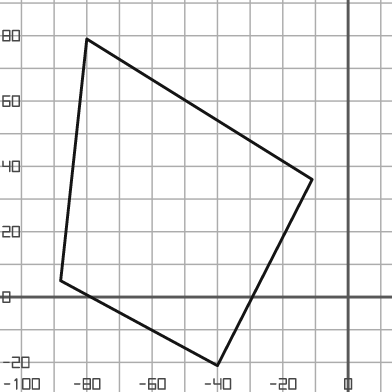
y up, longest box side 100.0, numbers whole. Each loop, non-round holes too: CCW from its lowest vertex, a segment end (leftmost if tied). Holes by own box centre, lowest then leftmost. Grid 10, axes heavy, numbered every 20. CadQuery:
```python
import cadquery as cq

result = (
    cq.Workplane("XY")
    .moveTo(-40.0, -21.0)
    .lineTo(-11.0, 36.0)
    .lineTo(-80.0, 79.0)
    .lineTo(-88.0, 5.0)
    .close()
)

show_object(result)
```